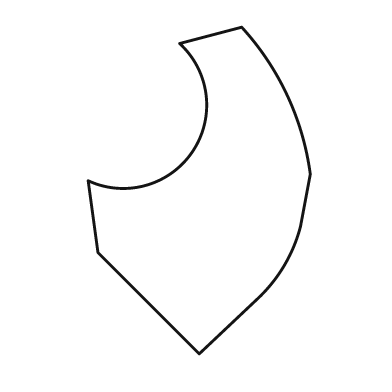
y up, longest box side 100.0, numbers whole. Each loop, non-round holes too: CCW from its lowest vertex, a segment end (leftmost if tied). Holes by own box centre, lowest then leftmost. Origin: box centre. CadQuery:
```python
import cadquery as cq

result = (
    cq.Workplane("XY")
    .moveTo(0.0, -50.0)
    .lineTo(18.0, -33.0)
    .threePointArc((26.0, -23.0), (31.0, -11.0))
    .lineTo(34.0, 5.0)
    .threePointArc((27.0, 29.0), (13.0, 50.0))
    .lineTo(-6.0, 45.0)
    .threePointArc((-2.0, 12.0), (-34.0, 3.0))
    .lineTo(-31.0, -19.0)
    .close()
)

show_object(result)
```